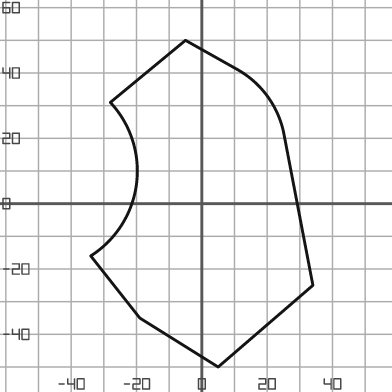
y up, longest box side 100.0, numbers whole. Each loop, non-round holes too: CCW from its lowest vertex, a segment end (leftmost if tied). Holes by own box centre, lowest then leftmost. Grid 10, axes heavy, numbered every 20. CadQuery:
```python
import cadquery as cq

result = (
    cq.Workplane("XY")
    .moveTo(5.0, -50.0)
    .lineTo(34.0, -25.0)
    .lineTo(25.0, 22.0)
    .threePointArc((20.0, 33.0), (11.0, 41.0))
    .lineTo(-5.0, 50.0)
    .lineTo(-28.0, 31.0)
    .threePointArc((-20.0, 6.0), (-34.0, -16.0))
    .lineTo(-19.0, -35.0)
    .close()
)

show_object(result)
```